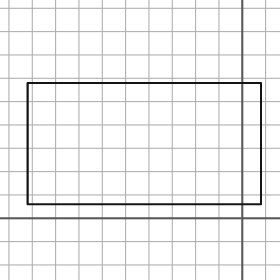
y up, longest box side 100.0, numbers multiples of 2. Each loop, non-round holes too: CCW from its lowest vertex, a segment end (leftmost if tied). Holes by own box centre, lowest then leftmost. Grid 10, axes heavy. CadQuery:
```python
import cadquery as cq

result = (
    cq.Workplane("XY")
    .moveTo(-92.0, 6.0)
    .lineTo(8.0, 6.0)
    .lineTo(8.0, 58.0)
    .lineTo(-92.0, 58.0)
    .close()
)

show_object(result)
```